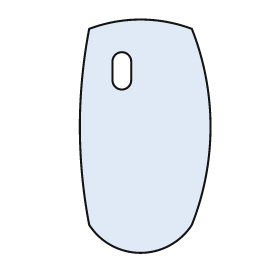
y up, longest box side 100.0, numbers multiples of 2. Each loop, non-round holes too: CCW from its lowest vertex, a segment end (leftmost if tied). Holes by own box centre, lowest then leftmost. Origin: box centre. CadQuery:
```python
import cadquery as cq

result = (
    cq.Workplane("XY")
    .moveTo(-24.0, -38.0)
    .threePointArc((-2.0, -50.0), (20.0, -38.0))
    .threePointArc((28.0, 4.0), (20.0, 46.0))
    .threePointArc((-2.0, 50.0), (-24.0, 46.0))
    .threePointArc((-28.0, 4.0), (-24.0, -38.0))
    .close()
    .moveTo(-14.0, 24.0)
    .threePointArc((-10.0, 20.0), (-6.0, 24.0))
    .lineTo(-6.0, 32.0)
    .threePointArc((-10.0, 36.0), (-14.0, 32.0))
    .close()
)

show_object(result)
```